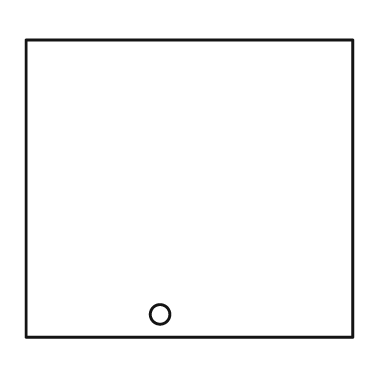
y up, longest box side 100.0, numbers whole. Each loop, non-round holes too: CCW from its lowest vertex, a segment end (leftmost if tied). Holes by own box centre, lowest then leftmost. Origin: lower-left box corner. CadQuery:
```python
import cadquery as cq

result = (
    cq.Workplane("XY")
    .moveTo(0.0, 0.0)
    .lineTo(100.0, 0.0)
    .lineTo(100.0, 91.0)
    .lineTo(0.0, 91.0)
    .close()
    .moveTo(41.0, 7.0)
    .circle(3.0)
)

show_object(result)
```